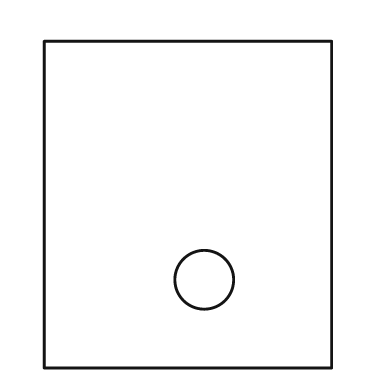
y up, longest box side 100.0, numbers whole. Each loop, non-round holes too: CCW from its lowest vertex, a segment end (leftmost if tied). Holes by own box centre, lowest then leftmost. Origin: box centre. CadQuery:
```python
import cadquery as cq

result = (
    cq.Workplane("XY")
    .moveTo(-44.0, -50.0)
    .lineTo(44.0, -50.0)
    .lineTo(44.0, 50.0)
    .lineTo(-44.0, 50.0)
    .close()
    .moveTo(5.0, -23.0)
    .circle(9.0)
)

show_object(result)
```